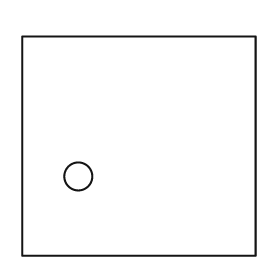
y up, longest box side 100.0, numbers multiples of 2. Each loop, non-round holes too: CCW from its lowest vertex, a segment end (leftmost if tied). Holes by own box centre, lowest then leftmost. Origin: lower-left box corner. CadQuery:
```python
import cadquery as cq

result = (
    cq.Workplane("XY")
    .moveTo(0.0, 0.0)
    .lineTo(100.0, 0.0)
    .lineTo(100.0, 94.0)
    .lineTo(0.0, 94.0)
    .close()
    .moveTo(24.0, 34.0)
    .circle(6.0)
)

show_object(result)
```